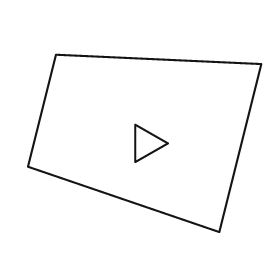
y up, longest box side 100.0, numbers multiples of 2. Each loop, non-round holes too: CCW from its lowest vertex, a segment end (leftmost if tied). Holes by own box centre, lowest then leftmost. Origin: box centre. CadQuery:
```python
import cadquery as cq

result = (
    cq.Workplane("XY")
    .moveTo(32.0, -38.0)
    .lineTo(50.0, 34.0)
    .lineTo(-38.0, 38.0)
    .lineTo(-50.0, -10.0)
    .close()
    .moveTo(-4.0, -8.0)
    .lineTo(10.0, 0.0)
    .lineTo(-4.0, 8.0)
    .close()
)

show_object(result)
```